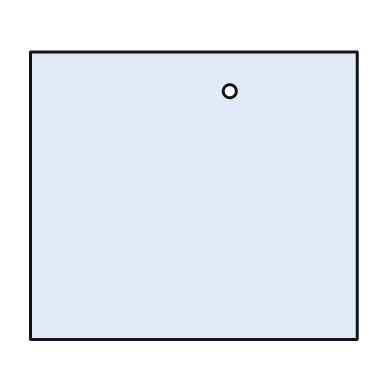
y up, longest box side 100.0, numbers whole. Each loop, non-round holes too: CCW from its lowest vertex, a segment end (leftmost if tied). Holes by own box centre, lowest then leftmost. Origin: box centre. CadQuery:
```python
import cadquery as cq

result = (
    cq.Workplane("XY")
    .moveTo(-50.0, -44.0)
    .lineTo(50.0, -44.0)
    .lineTo(50.0, 44.0)
    .lineTo(-50.0, 44.0)
    .close()
    .moveTo(11.0, 32.0)
    .circle(2.0)
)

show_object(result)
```